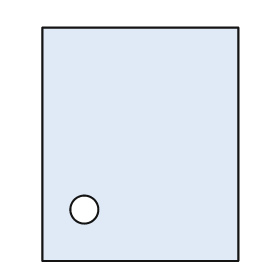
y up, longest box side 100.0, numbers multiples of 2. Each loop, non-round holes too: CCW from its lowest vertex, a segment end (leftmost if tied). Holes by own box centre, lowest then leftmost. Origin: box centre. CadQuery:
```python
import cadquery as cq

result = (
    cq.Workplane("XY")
    .moveTo(-42.0, -50.0)
    .lineTo(42.0, -50.0)
    .lineTo(42.0, 50.0)
    .lineTo(-42.0, 50.0)
    .close()
    .moveTo(-24.0, -28.0)
    .circle(6.0)
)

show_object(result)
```